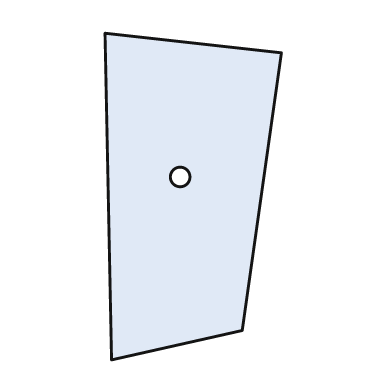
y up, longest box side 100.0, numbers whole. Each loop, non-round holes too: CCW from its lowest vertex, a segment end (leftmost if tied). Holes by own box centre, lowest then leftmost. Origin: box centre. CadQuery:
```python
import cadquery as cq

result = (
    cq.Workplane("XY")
    .moveTo(-25.0, -50.0)
    .lineTo(15.0, -41.0)
    .lineTo(27.0, 44.0)
    .lineTo(-27.0, 50.0)
    .close()
    .moveTo(-4.0, 6.0)
    .circle(3.0)
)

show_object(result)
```